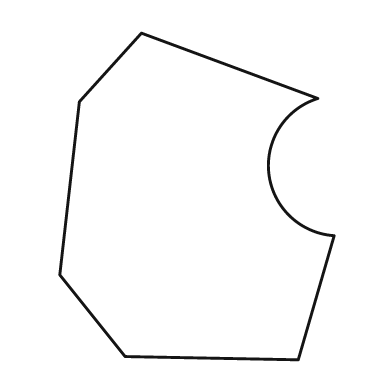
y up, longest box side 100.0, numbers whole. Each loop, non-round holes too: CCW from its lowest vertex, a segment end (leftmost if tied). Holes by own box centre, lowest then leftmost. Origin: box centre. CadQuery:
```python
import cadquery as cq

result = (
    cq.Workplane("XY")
    .moveTo(31.0, -50.0)
    .lineTo(42.0, -12.0)
    .threePointArc((22.0, 7.0), (37.0, 30.0))
    .lineTo(-17.0, 50.0)
    .lineTo(-36.0, 29.0)
    .lineTo(-42.0, -24.0)
    .lineTo(-22.0, -49.0)
    .close()
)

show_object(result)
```